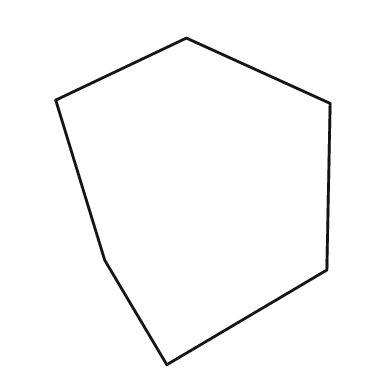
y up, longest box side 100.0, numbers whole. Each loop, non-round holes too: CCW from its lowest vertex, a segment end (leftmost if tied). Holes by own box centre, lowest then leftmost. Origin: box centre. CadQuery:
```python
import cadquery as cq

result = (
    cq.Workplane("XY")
    .moveTo(-8.0, -50.0)
    .lineTo(41.0, -21.0)
    .lineTo(42.0, 30.0)
    .lineTo(-2.0, 50.0)
    .lineTo(-42.0, 31.0)
    .lineTo(-27.0, -18.0)
    .close()
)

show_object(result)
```